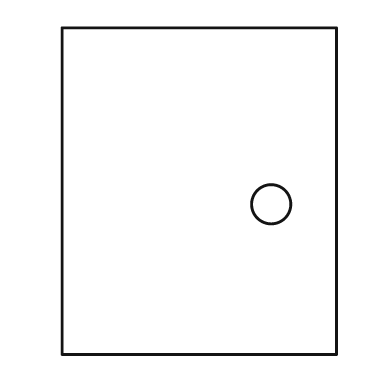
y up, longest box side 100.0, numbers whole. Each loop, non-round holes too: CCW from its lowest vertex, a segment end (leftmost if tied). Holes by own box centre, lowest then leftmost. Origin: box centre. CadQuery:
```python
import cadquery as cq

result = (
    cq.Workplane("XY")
    .moveTo(-42.0, -50.0)
    .lineTo(42.0, -50.0)
    .lineTo(42.0, 50.0)
    .lineTo(-42.0, 50.0)
    .close()
    .moveTo(22.0, -4.0)
    .circle(6.0)
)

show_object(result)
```